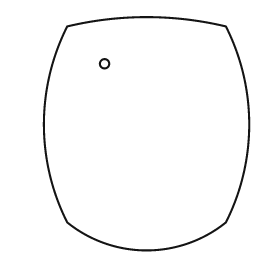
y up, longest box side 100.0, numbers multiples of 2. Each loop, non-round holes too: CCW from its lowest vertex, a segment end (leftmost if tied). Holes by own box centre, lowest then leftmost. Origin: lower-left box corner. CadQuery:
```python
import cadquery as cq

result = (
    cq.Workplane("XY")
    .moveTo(10.0, 12.0)
    .threePointArc((44.0, 0.0), (78.0, 12.0))
    .threePointArc((88.0, 54.0), (78.0, 96.0))
    .threePointArc((44.0, 100.0), (10.0, 96.0))
    .threePointArc((0.0, 54.0), (10.0, 12.0))
    .close()
    .moveTo(26.0, 80.0)
    .circle(2.0)
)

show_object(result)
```